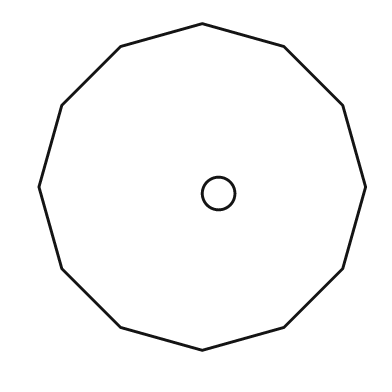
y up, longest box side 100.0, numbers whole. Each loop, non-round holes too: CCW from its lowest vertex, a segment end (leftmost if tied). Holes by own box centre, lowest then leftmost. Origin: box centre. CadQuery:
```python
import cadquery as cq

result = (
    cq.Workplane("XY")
    .moveTo(0.0, -50.0)
    .lineTo(25.0, -43.0)
    .lineTo(43.0, -25.0)
    .lineTo(50.0, 0.0)
    .lineTo(43.0, 25.0)
    .lineTo(25.0, 43.0)
    .lineTo(0.0, 50.0)
    .lineTo(-25.0, 43.0)
    .lineTo(-43.0, 25.0)
    .lineTo(-50.0, 0.0)
    .lineTo(-43.0, -25.0)
    .lineTo(-25.0, -43.0)
    .close()
    .moveTo(5.0, -2.0)
    .circle(5.0)
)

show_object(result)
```